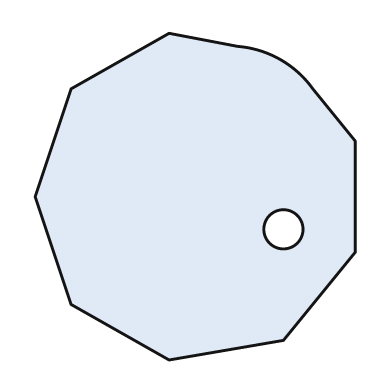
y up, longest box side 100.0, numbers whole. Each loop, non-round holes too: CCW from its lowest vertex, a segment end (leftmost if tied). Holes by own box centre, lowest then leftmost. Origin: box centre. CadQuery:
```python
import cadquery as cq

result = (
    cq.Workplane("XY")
    .moveTo(-8.0, -50.0)
    .lineTo(27.0, -44.0)
    .lineTo(49.0, -17.0)
    .lineTo(49.0, 17.0)
    .lineTo(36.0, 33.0)
    .threePointArc((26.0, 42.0), (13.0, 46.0))
    .lineTo(-8.0, 50.0)
    .lineTo(-38.0, 33.0)
    .lineTo(-49.0, 0.0)
    .lineTo(-38.0, -33.0)
    .close()
    .moveTo(27.0, -10.0)
    .circle(6.0)
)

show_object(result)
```